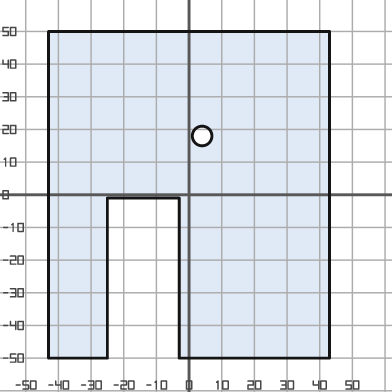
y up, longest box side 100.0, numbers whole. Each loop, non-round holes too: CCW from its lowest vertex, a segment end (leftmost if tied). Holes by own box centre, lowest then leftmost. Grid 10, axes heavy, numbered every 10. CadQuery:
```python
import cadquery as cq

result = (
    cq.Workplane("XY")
    .moveTo(-43.0, -50.0)
    .lineTo(-25.0, -50.0)
    .lineTo(-25.0, -1.0)
    .lineTo(-3.0, -1.0)
    .lineTo(-3.0, -50.0)
    .lineTo(43.0, -50.0)
    .lineTo(43.0, 50.0)
    .lineTo(-43.0, 50.0)
    .close()
    .moveTo(4.0, 18.0)
    .circle(3.0)
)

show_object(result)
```